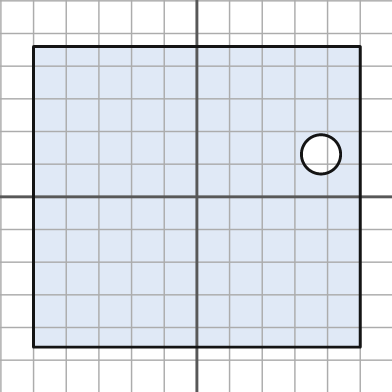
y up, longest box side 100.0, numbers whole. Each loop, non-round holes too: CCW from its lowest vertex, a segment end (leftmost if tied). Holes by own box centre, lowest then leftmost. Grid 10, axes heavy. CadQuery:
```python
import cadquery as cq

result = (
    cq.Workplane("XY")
    .moveTo(-50.0, -46.0)
    .lineTo(50.0, -46.0)
    .lineTo(50.0, 46.0)
    .lineTo(-50.0, 46.0)
    .close()
    .moveTo(38.0, 13.0)
    .circle(6.0)
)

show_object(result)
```